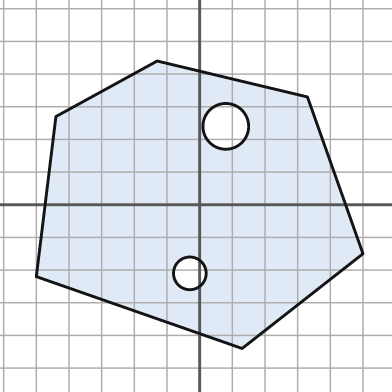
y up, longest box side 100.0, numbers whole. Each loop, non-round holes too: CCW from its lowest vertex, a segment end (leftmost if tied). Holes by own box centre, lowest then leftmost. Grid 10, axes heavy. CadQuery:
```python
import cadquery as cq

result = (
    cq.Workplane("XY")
    .moveTo(13.0, -44.0)
    .lineTo(50.0, -15.0)
    .lineTo(33.0, 33.0)
    .lineTo(-13.0, 44.0)
    .lineTo(-44.0, 27.0)
    .lineTo(-50.0, -22.0)
    .close()
    .moveTo(-3.0, -21.0)
    .circle(5.0)
    .moveTo(8.0, 24.0)
    .circle(7.0)
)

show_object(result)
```